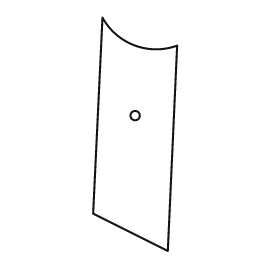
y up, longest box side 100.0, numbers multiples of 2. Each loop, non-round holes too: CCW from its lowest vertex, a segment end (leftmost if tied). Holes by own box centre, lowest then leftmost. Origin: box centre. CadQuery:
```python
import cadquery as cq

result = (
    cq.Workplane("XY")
    .moveTo(14.0, -50.0)
    .lineTo(18.0, 38.0)
    .threePointArc((0.0, 38.0), (-14.0, 50.0))
    .lineTo(-18.0, -34.0)
    .close()
    .moveTo(0.0, 8.0)
    .circle(2.0)
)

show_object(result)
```